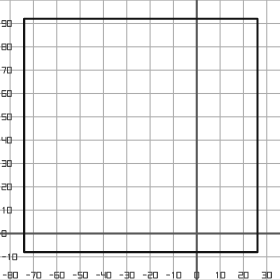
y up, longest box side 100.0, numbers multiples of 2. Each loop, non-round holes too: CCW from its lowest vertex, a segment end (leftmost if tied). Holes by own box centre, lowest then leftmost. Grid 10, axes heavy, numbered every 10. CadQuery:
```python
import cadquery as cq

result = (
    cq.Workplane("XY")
    .moveTo(-74.0, -8.0)
    .lineTo(26.0, -8.0)
    .lineTo(26.0, 92.0)
    .lineTo(-74.0, 92.0)
    .close()
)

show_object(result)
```